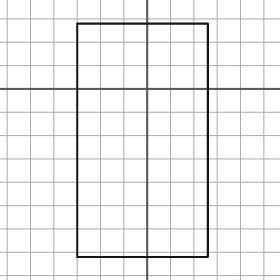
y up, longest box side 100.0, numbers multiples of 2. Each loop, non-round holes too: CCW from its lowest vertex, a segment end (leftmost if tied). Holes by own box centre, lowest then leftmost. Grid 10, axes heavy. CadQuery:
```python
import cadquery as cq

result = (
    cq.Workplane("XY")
    .moveTo(-30.0, -72.0)
    .lineTo(26.0, -72.0)
    .lineTo(26.0, 28.0)
    .lineTo(-30.0, 28.0)
    .close()
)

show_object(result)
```